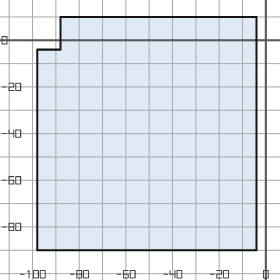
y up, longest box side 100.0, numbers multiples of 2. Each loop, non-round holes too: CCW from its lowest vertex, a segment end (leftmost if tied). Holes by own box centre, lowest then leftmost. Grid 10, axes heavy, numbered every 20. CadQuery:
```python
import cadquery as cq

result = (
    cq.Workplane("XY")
    .moveTo(-98.0, -90.0)
    .lineTo(-4.0, -90.0)
    .lineTo(-4.0, 10.0)
    .lineTo(-88.0, 10.0)
    .lineTo(-88.0, -4.0)
    .lineTo(-98.0, -4.0)
    .close()
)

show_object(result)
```